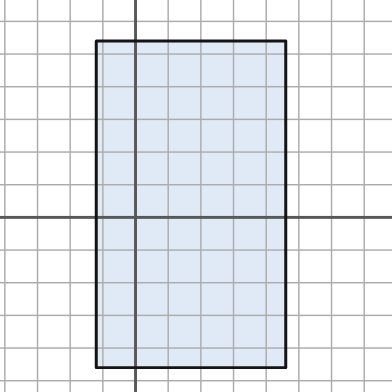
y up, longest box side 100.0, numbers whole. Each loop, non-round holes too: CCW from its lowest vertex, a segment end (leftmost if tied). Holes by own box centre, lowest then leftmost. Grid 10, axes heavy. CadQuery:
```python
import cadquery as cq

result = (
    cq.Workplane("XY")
    .moveTo(-12.0, -46.0)
    .lineTo(46.0, -46.0)
    .lineTo(46.0, 54.0)
    .lineTo(-12.0, 54.0)
    .close()
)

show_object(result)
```